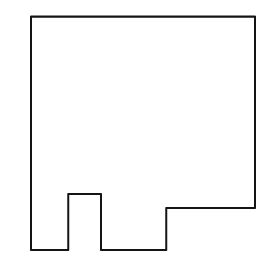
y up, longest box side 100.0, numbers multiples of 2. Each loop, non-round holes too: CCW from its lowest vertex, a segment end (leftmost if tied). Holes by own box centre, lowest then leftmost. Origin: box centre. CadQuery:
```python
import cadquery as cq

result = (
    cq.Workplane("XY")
    .moveTo(-48.0, -50.0)
    .lineTo(-32.0, -50.0)
    .lineTo(-32.0, -26.0)
    .lineTo(-18.0, -26.0)
    .lineTo(-18.0, -50.0)
    .lineTo(10.0, -50.0)
    .lineTo(10.0, -32.0)
    .lineTo(48.0, -32.0)
    .lineTo(48.0, 50.0)
    .lineTo(-48.0, 50.0)
    .close()
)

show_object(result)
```